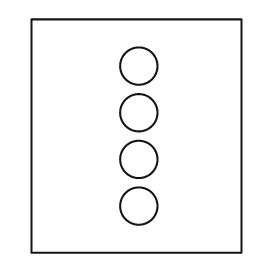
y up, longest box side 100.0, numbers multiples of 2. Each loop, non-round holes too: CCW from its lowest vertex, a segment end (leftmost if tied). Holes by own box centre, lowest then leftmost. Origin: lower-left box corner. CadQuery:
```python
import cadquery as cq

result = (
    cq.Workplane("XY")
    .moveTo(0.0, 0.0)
    .lineTo(90.0, 0.0)
    .lineTo(90.0, 100.0)
    .lineTo(0.0, 100.0)
    .close()
    .moveTo(46.0, 20.0)
    .circle(8.0)
    .moveTo(46.0, 40.0)
    .circle(8.0)
    .moveTo(46.0, 60.0)
    .circle(8.0)
    .moveTo(46.0, 80.0)
    .circle(8.0)
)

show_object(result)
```